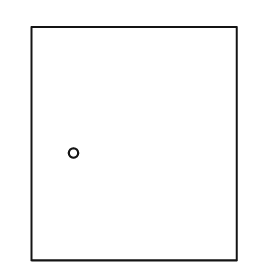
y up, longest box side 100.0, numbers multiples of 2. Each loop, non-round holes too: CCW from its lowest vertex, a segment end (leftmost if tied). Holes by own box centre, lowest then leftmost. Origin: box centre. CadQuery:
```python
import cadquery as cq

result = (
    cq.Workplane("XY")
    .moveTo(-44.0, -50.0)
    .lineTo(44.0, -50.0)
    .lineTo(44.0, 50.0)
    .lineTo(-44.0, 50.0)
    .close()
    .moveTo(-26.0, -4.0)
    .circle(2.0)
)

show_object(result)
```